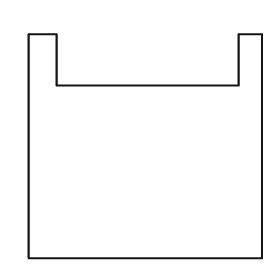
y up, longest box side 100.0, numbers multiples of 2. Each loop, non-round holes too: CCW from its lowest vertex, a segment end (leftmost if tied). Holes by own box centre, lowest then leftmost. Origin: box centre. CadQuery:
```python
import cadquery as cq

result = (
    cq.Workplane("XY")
    .moveTo(-50.0, -48.0)
    .lineTo(50.0, -48.0)
    .lineTo(50.0, 48.0)
    .lineTo(40.0, 48.0)
    .lineTo(40.0, 26.0)
    .lineTo(-38.0, 26.0)
    .lineTo(-38.0, 48.0)
    .lineTo(-50.0, 48.0)
    .close()
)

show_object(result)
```